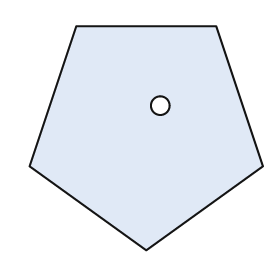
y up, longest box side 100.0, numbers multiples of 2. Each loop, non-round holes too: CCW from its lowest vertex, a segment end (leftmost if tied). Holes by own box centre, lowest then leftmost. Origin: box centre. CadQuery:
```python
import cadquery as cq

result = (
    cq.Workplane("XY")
    .moveTo(0.0, -48.0)
    .lineTo(50.0, -12.0)
    .lineTo(30.0, 48.0)
    .lineTo(-30.0, 48.0)
    .lineTo(-50.0, -12.0)
    .close()
    .moveTo(6.0, 14.0)
    .circle(4.0)
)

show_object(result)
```